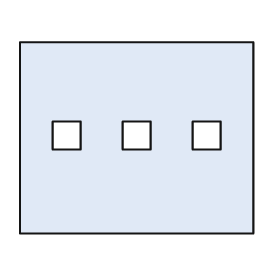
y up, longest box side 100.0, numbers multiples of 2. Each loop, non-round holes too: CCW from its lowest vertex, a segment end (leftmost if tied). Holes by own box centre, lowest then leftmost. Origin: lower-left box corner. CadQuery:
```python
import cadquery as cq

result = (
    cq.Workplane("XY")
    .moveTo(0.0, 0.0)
    .lineTo(100.0, 0.0)
    .lineTo(100.0, 82.0)
    .lineTo(0.0, 82.0)
    .close()
    .moveTo(14.0, 36.0)
    .lineTo(26.0, 36.0)
    .lineTo(26.0, 48.0)
    .lineTo(14.0, 48.0)
    .close()
    .moveTo(44.0, 36.0)
    .lineTo(56.0, 36.0)
    .lineTo(56.0, 48.0)
    .lineTo(44.0, 48.0)
    .close()
    .moveTo(74.0, 36.0)
    .lineTo(86.0, 36.0)
    .lineTo(86.0, 48.0)
    .lineTo(74.0, 48.0)
    .close()
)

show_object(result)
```